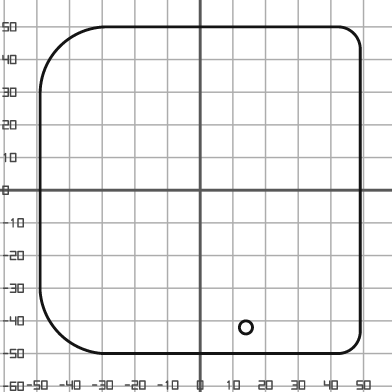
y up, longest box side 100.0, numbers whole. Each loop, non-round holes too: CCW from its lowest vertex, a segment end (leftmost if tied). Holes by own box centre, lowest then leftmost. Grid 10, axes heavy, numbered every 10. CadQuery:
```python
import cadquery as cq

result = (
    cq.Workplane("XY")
    .moveTo(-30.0, -50.0)
    .lineTo(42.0, -50.0)
    .threePointArc((47.0, -48.0), (49.0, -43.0))
    .lineTo(49.0, 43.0)
    .threePointArc((47.0, 48.0), (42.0, 50.0))
    .lineTo(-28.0, 50.0)
    .threePointArc((-43.0, 44.0), (-49.0, 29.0))
    .lineTo(-49.0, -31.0)
    .threePointArc((-43.0, -44.0), (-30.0, -50.0))
    .close()
    .moveTo(14.0, -42.0)
    .circle(2.0)
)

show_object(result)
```